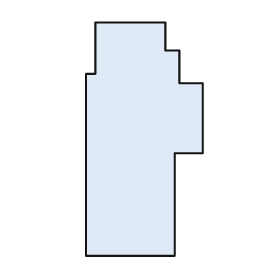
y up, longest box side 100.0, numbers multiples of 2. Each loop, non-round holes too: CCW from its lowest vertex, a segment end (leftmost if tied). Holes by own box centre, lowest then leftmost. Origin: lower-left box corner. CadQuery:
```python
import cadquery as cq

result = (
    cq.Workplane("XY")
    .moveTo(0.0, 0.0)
    .lineTo(38.0, 0.0)
    .lineTo(38.0, 44.0)
    .lineTo(50.0, 44.0)
    .lineTo(50.0, 74.0)
    .lineTo(40.0, 74.0)
    .lineTo(40.0, 88.0)
    .lineTo(34.0, 88.0)
    .lineTo(34.0, 100.0)
    .lineTo(4.0, 100.0)
    .lineTo(4.0, 78.0)
    .lineTo(0.0, 78.0)
    .close()
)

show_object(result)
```